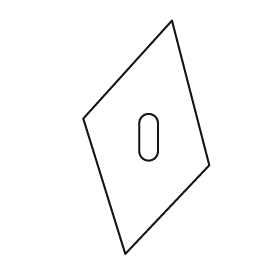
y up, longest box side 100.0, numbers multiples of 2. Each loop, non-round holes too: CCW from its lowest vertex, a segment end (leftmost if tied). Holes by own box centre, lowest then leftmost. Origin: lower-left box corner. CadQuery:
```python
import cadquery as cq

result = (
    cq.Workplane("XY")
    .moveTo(18.0, 0.0)
    .lineTo(54.0, 38.0)
    .lineTo(38.0, 100.0)
    .lineTo(0.0, 58.0)
    .close()
    .moveTo(24.0, 44.0)
    .threePointArc((28.0, 40.0), (32.0, 44.0))
    .lineTo(32.0, 56.0)
    .threePointArc((28.0, 60.0), (24.0, 56.0))
    .close()
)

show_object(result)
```